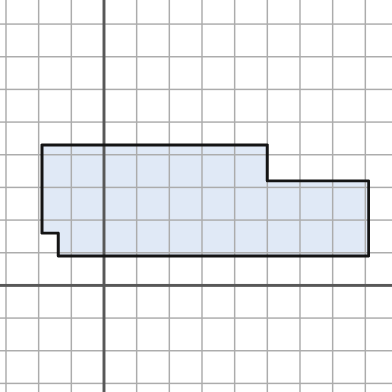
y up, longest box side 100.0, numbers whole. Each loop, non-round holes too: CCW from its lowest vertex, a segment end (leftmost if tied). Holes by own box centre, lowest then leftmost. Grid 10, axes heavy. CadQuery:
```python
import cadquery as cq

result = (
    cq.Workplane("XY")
    .moveTo(-14.0, 9.0)
    .lineTo(81.0, 9.0)
    .lineTo(81.0, 32.0)
    .lineTo(50.0, 32.0)
    .lineTo(50.0, 43.0)
    .lineTo(-19.0, 43.0)
    .lineTo(-19.0, 16.0)
    .lineTo(-14.0, 16.0)
    .close()
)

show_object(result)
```